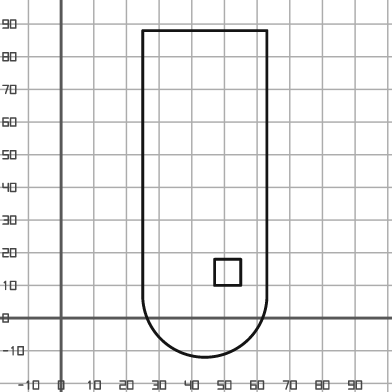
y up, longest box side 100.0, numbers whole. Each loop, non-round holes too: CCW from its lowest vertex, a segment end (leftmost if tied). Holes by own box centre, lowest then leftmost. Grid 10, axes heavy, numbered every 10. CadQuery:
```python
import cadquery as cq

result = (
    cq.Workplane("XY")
    .moveTo(25.0, 6.0)
    .threePointArc((44.0, -12.0), (63.0, 6.0))
    .lineTo(63.0, 88.0)
    .lineTo(25.0, 88.0)
    .close()
    .moveTo(47.0, 10.0)
    .lineTo(55.0, 10.0)
    .lineTo(55.0, 18.0)
    .lineTo(47.0, 18.0)
    .close()
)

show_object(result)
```